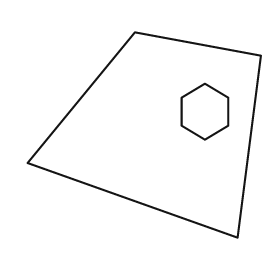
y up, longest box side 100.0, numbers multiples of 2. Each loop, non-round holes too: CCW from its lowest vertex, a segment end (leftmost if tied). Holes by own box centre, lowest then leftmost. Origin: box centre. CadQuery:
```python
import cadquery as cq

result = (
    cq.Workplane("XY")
    .moveTo(40.0, -44.0)
    .lineTo(50.0, 34.0)
    .lineTo(-4.0, 44.0)
    .lineTo(-50.0, -12.0)
    .close()
    .moveTo(26.0, -2.0)
    .lineTo(36.0, 4.0)
    .lineTo(36.0, 16.0)
    .lineTo(26.0, 22.0)
    .lineTo(16.0, 16.0)
    .lineTo(16.0, 4.0)
    .close()
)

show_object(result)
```